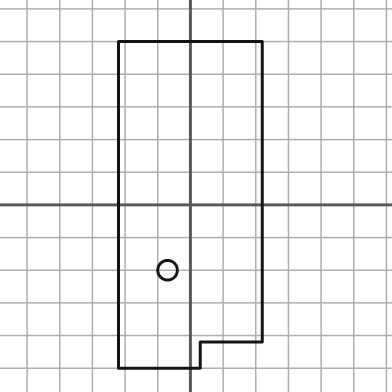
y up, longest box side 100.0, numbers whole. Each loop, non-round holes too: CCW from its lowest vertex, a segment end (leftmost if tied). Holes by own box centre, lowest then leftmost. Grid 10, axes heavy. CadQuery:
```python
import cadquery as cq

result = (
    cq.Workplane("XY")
    .moveTo(-22.0, -50.0)
    .lineTo(3.0, -50.0)
    .lineTo(3.0, -42.0)
    .lineTo(22.0, -42.0)
    .lineTo(22.0, 50.0)
    .lineTo(-22.0, 50.0)
    .close()
    .moveTo(-7.0, -20.0)
    .circle(3.0)
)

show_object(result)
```